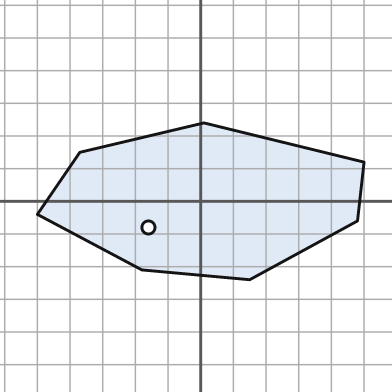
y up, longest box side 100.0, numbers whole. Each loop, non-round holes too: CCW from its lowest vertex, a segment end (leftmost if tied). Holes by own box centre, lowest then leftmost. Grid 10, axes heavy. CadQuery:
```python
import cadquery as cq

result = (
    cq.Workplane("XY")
    .moveTo(15.0, -24.0)
    .lineTo(48.0, -6.0)
    .lineTo(50.0, 12.0)
    .lineTo(1.0, 24.0)
    .lineTo(-37.0, 15.0)
    .lineTo(-50.0, -4.0)
    .lineTo(-18.0, -21.0)
    .close()
    .moveTo(-16.0, -8.0)
    .circle(2.0)
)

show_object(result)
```